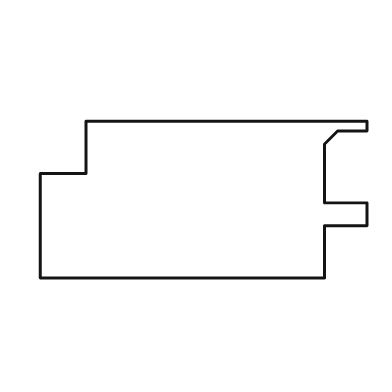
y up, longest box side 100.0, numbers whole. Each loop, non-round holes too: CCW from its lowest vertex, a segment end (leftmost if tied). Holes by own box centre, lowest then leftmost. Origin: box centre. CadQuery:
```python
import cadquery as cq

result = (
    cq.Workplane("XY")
    .moveTo(-50.0, -24.0)
    .lineTo(37.0, -24.0)
    .lineTo(37.0, -8.0)
    .lineTo(50.0, -8.0)
    .lineTo(50.0, -1.0)
    .lineTo(37.0, -1.0)
    .lineTo(37.0, 17.0)
    .lineTo(41.0, 21.0)
    .lineTo(50.0, 21.0)
    .lineTo(50.0, 24.0)
    .lineTo(-36.0, 24.0)
    .lineTo(-36.0, 8.0)
    .lineTo(-50.0, 8.0)
    .close()
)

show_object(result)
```